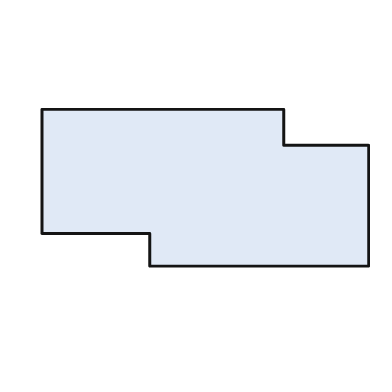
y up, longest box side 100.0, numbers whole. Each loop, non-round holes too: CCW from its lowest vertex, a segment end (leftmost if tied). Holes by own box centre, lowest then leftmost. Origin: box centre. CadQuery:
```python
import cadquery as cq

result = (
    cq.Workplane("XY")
    .moveTo(-17.0, -24.0)
    .lineTo(50.0, -24.0)
    .lineTo(50.0, 13.0)
    .lineTo(24.0, 13.0)
    .lineTo(24.0, 24.0)
    .lineTo(-50.0, 24.0)
    .lineTo(-50.0, -14.0)
    .lineTo(-17.0, -14.0)
    .close()
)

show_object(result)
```